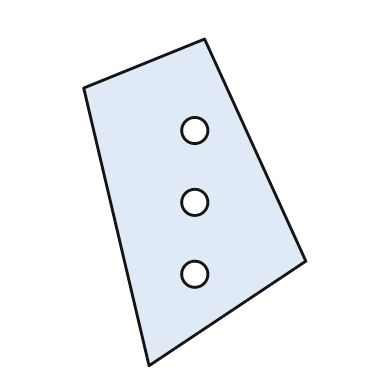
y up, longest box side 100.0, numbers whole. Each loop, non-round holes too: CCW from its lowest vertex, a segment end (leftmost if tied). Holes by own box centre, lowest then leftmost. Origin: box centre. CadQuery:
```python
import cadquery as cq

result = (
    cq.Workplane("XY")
    .moveTo(-14.0, -50.0)
    .lineTo(34.0, -18.0)
    .lineTo(3.0, 50.0)
    .lineTo(-34.0, 35.0)
    .close()
    .moveTo(0.0, -22.0)
    .circle(4.0)
    .moveTo(0.0, 0.0)
    .circle(4.0)
    .moveTo(0.0, 22.0)
    .circle(4.0)
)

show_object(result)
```